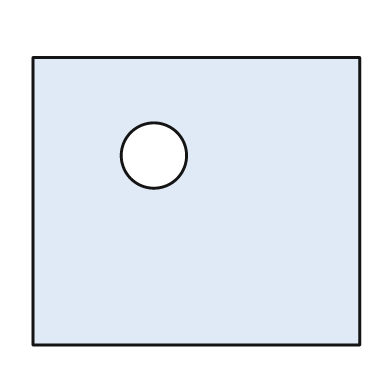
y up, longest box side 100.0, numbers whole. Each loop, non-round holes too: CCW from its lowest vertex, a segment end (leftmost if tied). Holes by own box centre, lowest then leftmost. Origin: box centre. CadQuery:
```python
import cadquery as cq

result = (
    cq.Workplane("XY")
    .moveTo(-50.0, -44.0)
    .lineTo(50.0, -44.0)
    .lineTo(50.0, 44.0)
    .lineTo(-50.0, 44.0)
    .close()
    .moveTo(-13.0, 14.0)
    .circle(10.0)
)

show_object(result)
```